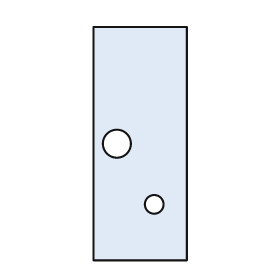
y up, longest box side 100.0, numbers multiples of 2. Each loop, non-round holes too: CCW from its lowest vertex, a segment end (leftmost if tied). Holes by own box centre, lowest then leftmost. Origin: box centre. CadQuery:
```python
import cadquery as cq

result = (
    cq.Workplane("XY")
    .moveTo(-20.0, -50.0)
    .lineTo(20.0, -50.0)
    .lineTo(20.0, 50.0)
    .lineTo(-20.0, 50.0)
    .close()
    .moveTo(6.0, -26.0)
    .circle(4.0)
    .moveTo(-10.0, 0.0)
    .circle(6.0)
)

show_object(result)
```